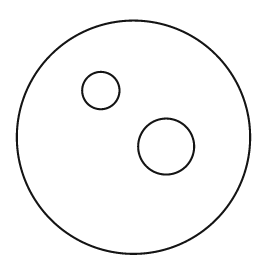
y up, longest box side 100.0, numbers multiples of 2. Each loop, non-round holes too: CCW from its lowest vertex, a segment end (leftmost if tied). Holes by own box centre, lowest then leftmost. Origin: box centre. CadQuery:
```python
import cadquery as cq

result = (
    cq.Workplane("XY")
    .moveTo(0.0, 0.0)
    .circle(50.0)
    .moveTo(14.0, -4.0)
    .circle(12.0)
    .moveTo(-14.0, 20.0)
    .circle(8.0)
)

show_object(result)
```